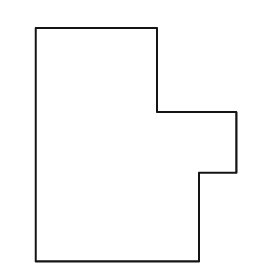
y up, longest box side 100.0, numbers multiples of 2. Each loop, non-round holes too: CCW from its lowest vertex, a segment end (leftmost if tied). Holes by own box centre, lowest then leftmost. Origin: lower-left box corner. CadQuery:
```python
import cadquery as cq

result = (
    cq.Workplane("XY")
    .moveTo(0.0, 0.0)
    .lineTo(70.0, 0.0)
    .lineTo(70.0, 38.0)
    .lineTo(86.0, 38.0)
    .lineTo(86.0, 64.0)
    .lineTo(52.0, 64.0)
    .lineTo(52.0, 100.0)
    .lineTo(0.0, 100.0)
    .close()
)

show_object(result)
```